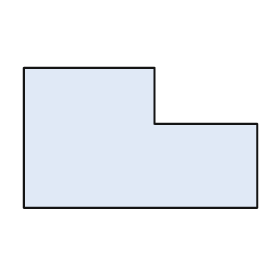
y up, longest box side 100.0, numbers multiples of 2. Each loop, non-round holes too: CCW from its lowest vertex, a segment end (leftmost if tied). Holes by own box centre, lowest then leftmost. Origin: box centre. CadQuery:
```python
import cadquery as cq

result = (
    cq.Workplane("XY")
    .moveTo(-50.0, -30.0)
    .lineTo(50.0, -30.0)
    .lineTo(50.0, 6.0)
    .lineTo(6.0, 6.0)
    .lineTo(6.0, 30.0)
    .lineTo(-50.0, 30.0)
    .close()
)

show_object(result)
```